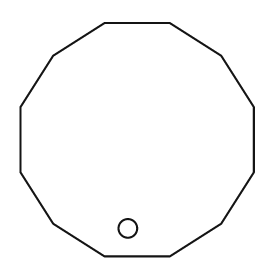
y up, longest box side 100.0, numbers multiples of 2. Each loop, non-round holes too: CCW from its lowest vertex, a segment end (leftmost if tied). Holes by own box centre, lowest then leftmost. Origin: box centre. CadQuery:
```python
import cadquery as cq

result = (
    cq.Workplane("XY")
    .moveTo(-14.0, -50.0)
    .lineTo(14.0, -50.0)
    .lineTo(36.0, -36.0)
    .lineTo(50.0, -14.0)
    .lineTo(50.0, 14.0)
    .lineTo(36.0, 36.0)
    .lineTo(14.0, 50.0)
    .lineTo(-14.0, 50.0)
    .lineTo(-36.0, 36.0)
    .lineTo(-50.0, 14.0)
    .lineTo(-50.0, -14.0)
    .lineTo(-36.0, -36.0)
    .close()
    .moveTo(-4.0, -38.0)
    .circle(4.0)
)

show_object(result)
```